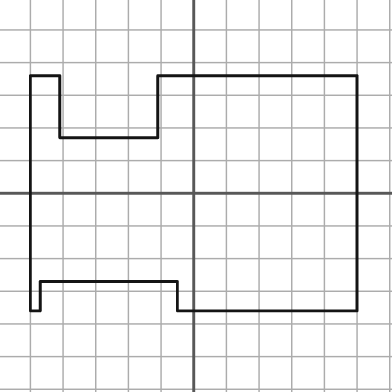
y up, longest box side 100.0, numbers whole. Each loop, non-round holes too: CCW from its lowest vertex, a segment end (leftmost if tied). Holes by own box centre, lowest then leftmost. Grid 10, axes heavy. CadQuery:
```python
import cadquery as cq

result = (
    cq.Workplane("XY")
    .moveTo(-50.0, -36.0)
    .lineTo(-47.0, -36.0)
    .lineTo(-47.0, -27.0)
    .lineTo(-5.0, -27.0)
    .lineTo(-5.0, -36.0)
    .lineTo(50.0, -36.0)
    .lineTo(50.0, 36.0)
    .lineTo(-11.0, 36.0)
    .lineTo(-11.0, 17.0)
    .lineTo(-41.0, 17.0)
    .lineTo(-41.0, 36.0)
    .lineTo(-50.0, 36.0)
    .close()
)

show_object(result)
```